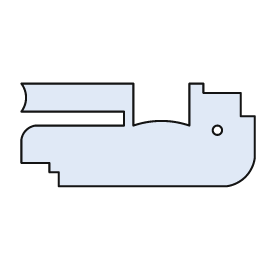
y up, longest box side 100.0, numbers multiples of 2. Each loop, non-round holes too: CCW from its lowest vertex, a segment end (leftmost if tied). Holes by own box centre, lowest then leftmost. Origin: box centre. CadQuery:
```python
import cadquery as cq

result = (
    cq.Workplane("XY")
    .moveTo(-34.0, -22.0)
    .lineTo(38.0, -22.0)
    .threePointArc((46.0, -18.0), (50.0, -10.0))
    .lineTo(50.0, 8.0)
    .lineTo(44.0, 8.0)
    .lineTo(44.0, 18.0)
    .lineTo(28.0, 18.0)
    .lineTo(28.0, 22.0)
    .lineTo(22.0, 22.0)
    .lineTo(22.0, 4.0)
    .threePointArc((10.0, 6.0), (-2.0, 4.0))
    .lineTo(-2.0, 22.0)
    .lineTo(-50.0, 22.0)
    .threePointArc((-48.0, 16.0), (-50.0, 10.0))
    .lineTo(-6.0, 10.0)
    .lineTo(-6.0, 4.0)
    .lineTo(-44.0, 4.0)
    .threePointArc((-48.0, 2.0), (-50.0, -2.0))
    .lineTo(-50.0, -12.0)
    .lineTo(-38.0, -12.0)
    .lineTo(-38.0, -16.0)
    .lineTo(-34.0, -16.0)
    .close()
    .moveTo(34.0, 2.0)
    .circle(2.0)
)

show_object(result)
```